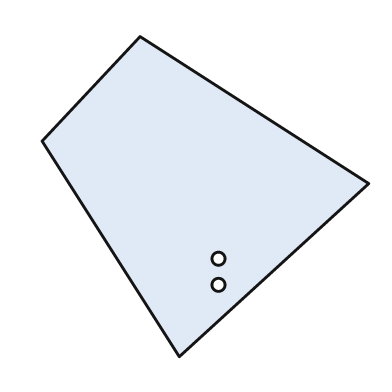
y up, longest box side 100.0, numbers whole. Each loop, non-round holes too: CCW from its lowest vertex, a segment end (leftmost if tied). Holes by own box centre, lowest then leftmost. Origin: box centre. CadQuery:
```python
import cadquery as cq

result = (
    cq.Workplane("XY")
    .moveTo(-8.0, -49.0)
    .lineTo(50.0, 4.0)
    .lineTo(-20.0, 49.0)
    .lineTo(-50.0, 17.0)
    .close()
    .moveTo(4.0, -27.0)
    .circle(2.0)
    .moveTo(4.0, -19.0)
    .circle(2.0)
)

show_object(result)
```